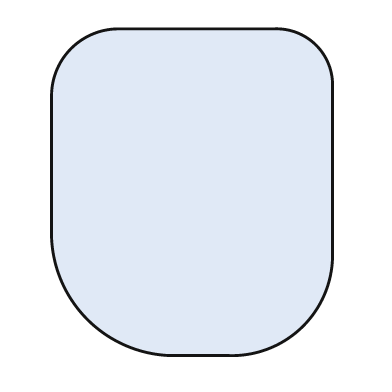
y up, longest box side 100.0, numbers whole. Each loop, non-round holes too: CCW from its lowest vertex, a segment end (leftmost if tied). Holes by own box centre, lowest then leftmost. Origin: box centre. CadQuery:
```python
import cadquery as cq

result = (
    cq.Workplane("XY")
    .moveTo(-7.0, -50.0)
    .lineTo(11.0, -50.0)
    .threePointArc((34.0, -41.0), (43.0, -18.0))
    .lineTo(43.0, 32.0)
    .threePointArc((38.0, 45.0), (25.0, 50.0))
    .lineTo(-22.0, 50.0)
    .threePointArc((-37.0, 44.0), (-43.0, 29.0))
    .lineTo(-43.0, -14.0)
    .threePointArc((-32.0, -39.0), (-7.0, -50.0))
    .close()
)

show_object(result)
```